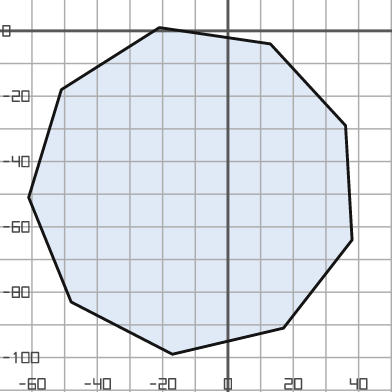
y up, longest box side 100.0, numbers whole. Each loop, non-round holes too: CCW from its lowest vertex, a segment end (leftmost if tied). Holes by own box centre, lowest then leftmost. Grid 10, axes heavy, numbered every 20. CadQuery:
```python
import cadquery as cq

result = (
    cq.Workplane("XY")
    .moveTo(-17.0, -99.0)
    .lineTo(17.0, -91.0)
    .lineTo(38.0, -64.0)
    .lineTo(36.0, -29.0)
    .lineTo(13.0, -4.0)
    .lineTo(-21.0, 1.0)
    .lineTo(-51.0, -18.0)
    .lineTo(-61.0, -51.0)
    .lineTo(-48.0, -83.0)
    .close()
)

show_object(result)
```